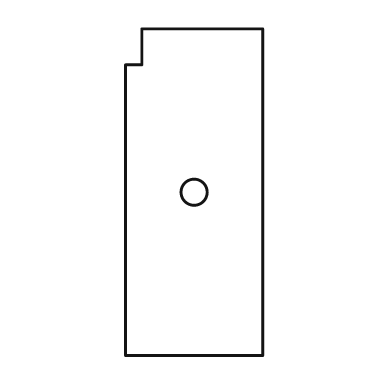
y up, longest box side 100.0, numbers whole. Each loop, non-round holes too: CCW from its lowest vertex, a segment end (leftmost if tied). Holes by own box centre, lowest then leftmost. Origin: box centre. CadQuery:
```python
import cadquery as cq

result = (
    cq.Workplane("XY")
    .moveTo(-21.0, -50.0)
    .lineTo(21.0, -50.0)
    .lineTo(21.0, 50.0)
    .lineTo(-16.0, 50.0)
    .lineTo(-16.0, 39.0)
    .lineTo(-21.0, 39.0)
    .close()
    .moveTo(0.0, 0.0)
    .circle(4.0)
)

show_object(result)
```